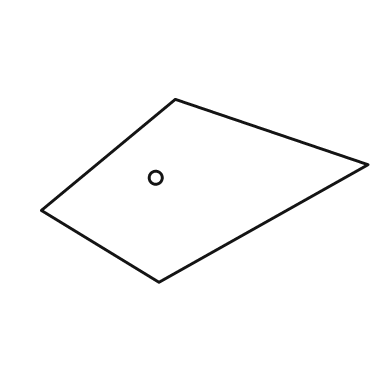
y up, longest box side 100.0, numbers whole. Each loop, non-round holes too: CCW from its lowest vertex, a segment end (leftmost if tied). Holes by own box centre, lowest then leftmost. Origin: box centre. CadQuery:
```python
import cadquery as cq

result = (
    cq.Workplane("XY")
    .moveTo(-14.0, -28.0)
    .lineTo(50.0, 8.0)
    .lineTo(-9.0, 28.0)
    .lineTo(-50.0, -6.0)
    .close()
    .moveTo(-15.0, 4.0)
    .circle(2.0)
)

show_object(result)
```